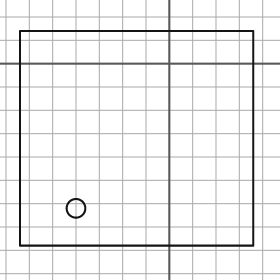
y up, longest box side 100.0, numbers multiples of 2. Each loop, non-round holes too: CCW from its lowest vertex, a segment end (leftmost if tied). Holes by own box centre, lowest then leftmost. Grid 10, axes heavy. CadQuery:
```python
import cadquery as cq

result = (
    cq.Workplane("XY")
    .moveTo(-64.0, -78.0)
    .lineTo(36.0, -78.0)
    .lineTo(36.0, 14.0)
    .lineTo(-64.0, 14.0)
    .close()
    .moveTo(-40.0, -62.0)
    .circle(4.0)
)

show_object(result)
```